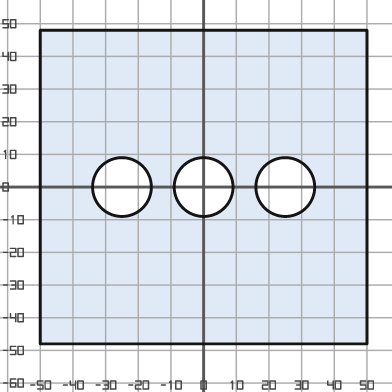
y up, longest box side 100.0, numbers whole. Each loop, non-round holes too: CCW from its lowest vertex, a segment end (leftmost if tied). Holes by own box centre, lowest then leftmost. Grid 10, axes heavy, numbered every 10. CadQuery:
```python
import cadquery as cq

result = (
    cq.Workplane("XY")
    .moveTo(-50.0, -48.0)
    .lineTo(50.0, -48.0)
    .lineTo(50.0, 48.0)
    .lineTo(-50.0, 48.0)
    .close()
    .moveTo(-25.0, 0.0)
    .circle(9.0)
    .moveTo(0.0, 0.0)
    .circle(9.0)
    .moveTo(25.0, 0.0)
    .circle(9.0)
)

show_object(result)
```